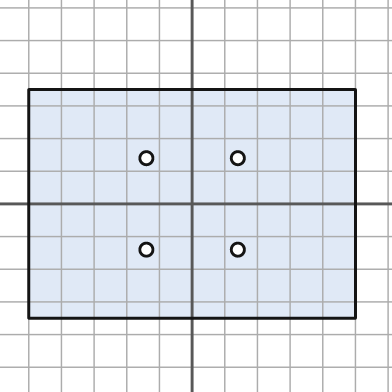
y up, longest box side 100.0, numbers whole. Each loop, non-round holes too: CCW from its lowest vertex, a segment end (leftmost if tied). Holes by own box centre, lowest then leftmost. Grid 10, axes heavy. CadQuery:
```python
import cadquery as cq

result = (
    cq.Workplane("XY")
    .moveTo(-50.0, -35.0)
    .lineTo(50.0, -35.0)
    .lineTo(50.0, 35.0)
    .lineTo(-50.0, 35.0)
    .close()
    .moveTo(-14.0, -14.0)
    .circle(2.0)
    .moveTo(14.0, -14.0)
    .circle(2.0)
    .moveTo(-14.0, 14.0)
    .circle(2.0)
    .moveTo(14.0, 14.0)
    .circle(2.0)
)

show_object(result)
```